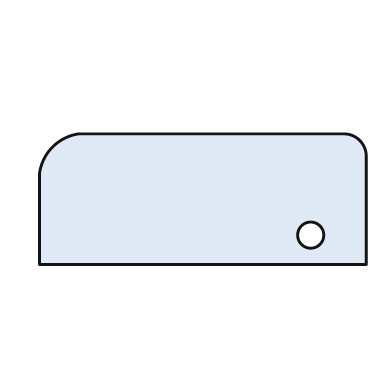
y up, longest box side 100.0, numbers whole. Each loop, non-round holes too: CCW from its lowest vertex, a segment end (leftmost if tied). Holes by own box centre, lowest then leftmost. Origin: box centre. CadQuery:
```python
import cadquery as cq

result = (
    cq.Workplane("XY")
    .moveTo(-50.0, -20.0)
    .lineTo(50.0, -20.0)
    .lineTo(50.0, 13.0)
    .threePointArc((48.0, 18.0), (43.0, 20.0))
    .lineTo(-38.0, 20.0)
    .threePointArc((-46.0, 16.0), (-50.0, 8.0))
    .close()
    .moveTo(33.0, -11.0)
    .circle(4.0)
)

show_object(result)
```